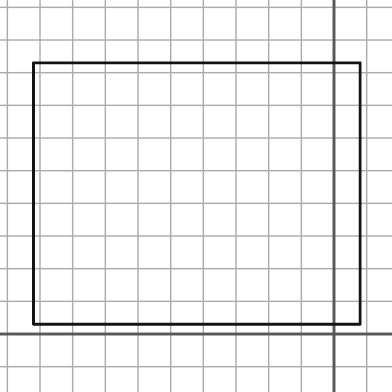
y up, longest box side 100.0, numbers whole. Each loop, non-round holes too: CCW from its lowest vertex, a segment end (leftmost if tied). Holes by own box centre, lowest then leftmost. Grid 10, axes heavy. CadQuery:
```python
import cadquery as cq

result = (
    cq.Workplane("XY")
    .moveTo(-92.0, 3.0)
    .lineTo(8.0, 3.0)
    .lineTo(8.0, 83.0)
    .lineTo(-92.0, 83.0)
    .close()
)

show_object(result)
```